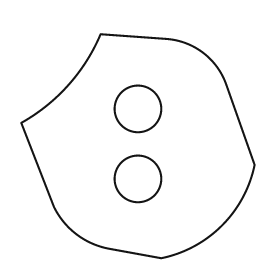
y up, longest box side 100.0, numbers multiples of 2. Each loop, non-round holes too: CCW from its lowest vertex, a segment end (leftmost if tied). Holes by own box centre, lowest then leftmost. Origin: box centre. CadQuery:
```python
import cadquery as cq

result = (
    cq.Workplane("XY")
    .moveTo(10.0, -48.0)
    .threePointArc((36.0, -34.0), (50.0, -8.0))
    .lineTo(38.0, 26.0)
    .threePointArc((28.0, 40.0), (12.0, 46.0))
    .lineTo(-16.0, 48.0)
    .threePointArc((-30.0, 26.0), (-50.0, 10.0))
    .lineTo(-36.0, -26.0)
    .threePointArc((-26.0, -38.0), (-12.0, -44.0))
    .close()
    .moveTo(0.0, -14.0)
    .circle(10.0)
    .moveTo(0.0, 16.0)
    .circle(10.0)
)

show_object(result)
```